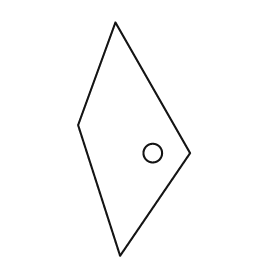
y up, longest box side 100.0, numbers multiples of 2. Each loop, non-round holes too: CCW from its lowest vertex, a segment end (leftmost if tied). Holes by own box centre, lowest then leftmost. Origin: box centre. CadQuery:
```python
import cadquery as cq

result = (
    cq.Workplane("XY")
    .moveTo(-6.0, -50.0)
    .lineTo(24.0, -6.0)
    .lineTo(-8.0, 50.0)
    .lineTo(-24.0, 6.0)
    .close()
    .moveTo(8.0, -6.0)
    .circle(4.0)
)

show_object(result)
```